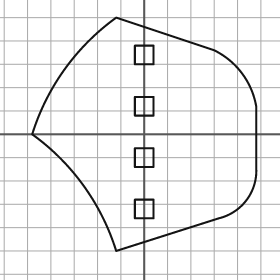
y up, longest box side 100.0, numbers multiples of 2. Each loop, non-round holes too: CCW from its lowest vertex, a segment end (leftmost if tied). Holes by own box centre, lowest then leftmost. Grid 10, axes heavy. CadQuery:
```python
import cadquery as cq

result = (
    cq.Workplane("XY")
    .moveTo(-12.0, -50.0)
    .lineTo(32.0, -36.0)
    .threePointArc((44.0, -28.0), (48.0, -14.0))
    .lineTo(48.0, 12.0)
    .threePointArc((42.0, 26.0), (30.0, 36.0))
    .lineTo(-12.0, 50.0)
    .threePointArc((-34.0, 28.0), (-48.0, 0.0))
    .threePointArc((-26.0, -22.0), (-12.0, -50.0))
    .close()
    .moveTo(-4.0, -36.0)
    .lineTo(4.0, -36.0)
    .lineTo(4.0, -28.0)
    .lineTo(-4.0, -28.0)
    .close()
    .moveTo(-4.0, -14.0)
    .lineTo(4.0, -14.0)
    .lineTo(4.0, -6.0)
    .lineTo(-4.0, -6.0)
    .close()
    .moveTo(-4.0, 8.0)
    .lineTo(4.0, 8.0)
    .lineTo(4.0, 16.0)
    .lineTo(-4.0, 16.0)
    .close()
    .moveTo(-4.0, 30.0)
    .lineTo(4.0, 30.0)
    .lineTo(4.0, 38.0)
    .lineTo(-4.0, 38.0)
    .close()
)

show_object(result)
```